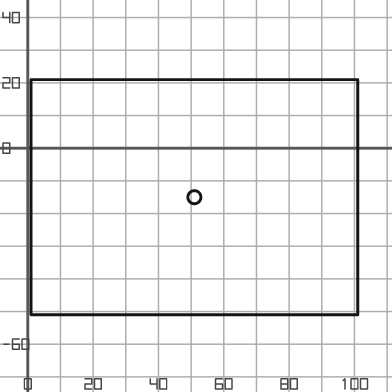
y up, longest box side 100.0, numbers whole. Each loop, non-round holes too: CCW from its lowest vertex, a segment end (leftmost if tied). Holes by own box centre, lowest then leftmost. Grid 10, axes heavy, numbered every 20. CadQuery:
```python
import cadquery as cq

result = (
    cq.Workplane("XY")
    .moveTo(1.0, -51.0)
    .lineTo(101.0, -51.0)
    .lineTo(101.0, 21.0)
    .lineTo(1.0, 21.0)
    .close()
    .moveTo(51.0, -15.0)
    .circle(2.0)
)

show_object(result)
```